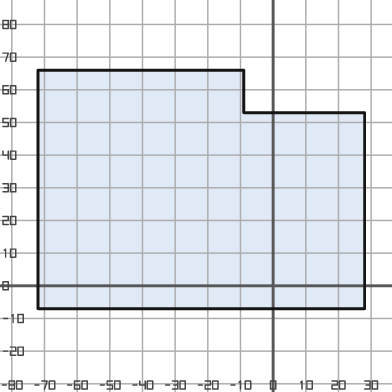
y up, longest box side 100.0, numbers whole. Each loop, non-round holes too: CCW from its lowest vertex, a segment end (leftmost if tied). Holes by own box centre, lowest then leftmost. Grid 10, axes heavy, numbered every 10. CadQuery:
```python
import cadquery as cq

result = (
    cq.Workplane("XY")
    .moveTo(-72.0, -7.0)
    .lineTo(28.0, -7.0)
    .lineTo(28.0, 53.0)
    .lineTo(-9.0, 53.0)
    .lineTo(-9.0, 66.0)
    .lineTo(-72.0, 66.0)
    .close()
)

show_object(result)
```